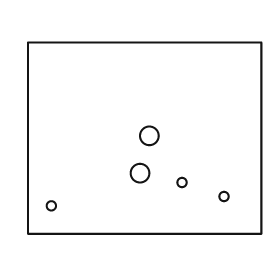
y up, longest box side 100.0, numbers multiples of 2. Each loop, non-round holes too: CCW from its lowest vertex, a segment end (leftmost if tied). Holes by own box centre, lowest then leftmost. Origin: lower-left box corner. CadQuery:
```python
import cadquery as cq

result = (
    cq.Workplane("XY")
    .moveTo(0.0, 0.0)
    .lineTo(100.0, 0.0)
    .lineTo(100.0, 82.0)
    .lineTo(0.0, 82.0)
    .close()
    .moveTo(10.0, 12.0)
    .circle(2.0)
    .moveTo(84.0, 16.0)
    .circle(2.0)
    .moveTo(66.0, 22.0)
    .circle(2.0)
    .moveTo(48.0, 26.0)
    .circle(4.0)
    .moveTo(52.0, 42.0)
    .circle(4.0)
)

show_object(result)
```